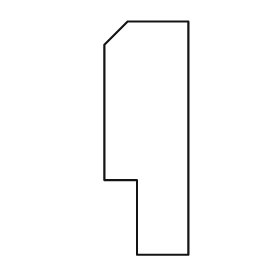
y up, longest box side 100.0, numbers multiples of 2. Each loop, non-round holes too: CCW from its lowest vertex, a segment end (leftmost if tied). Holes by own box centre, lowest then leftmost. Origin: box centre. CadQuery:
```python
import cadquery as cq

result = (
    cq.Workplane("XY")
    .moveTo(-4.0, -50.0)
    .lineTo(18.0, -50.0)
    .lineTo(18.0, 50.0)
    .lineTo(-8.0, 50.0)
    .lineTo(-18.0, 40.0)
    .lineTo(-18.0, -18.0)
    .lineTo(-4.0, -18.0)
    .close()
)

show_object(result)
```